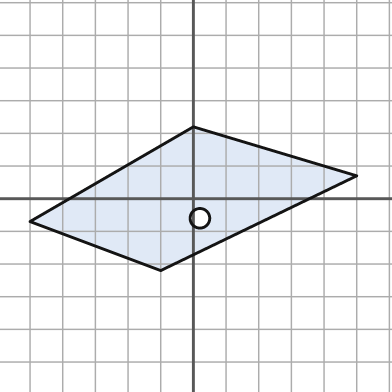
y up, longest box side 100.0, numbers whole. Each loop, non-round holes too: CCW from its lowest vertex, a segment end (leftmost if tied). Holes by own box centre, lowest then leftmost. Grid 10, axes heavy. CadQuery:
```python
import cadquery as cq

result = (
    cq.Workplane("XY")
    .moveTo(-10.0, -22.0)
    .lineTo(50.0, 7.0)
    .lineTo(0.0, 22.0)
    .lineTo(-50.0, -7.0)
    .close()
    .moveTo(2.0, -6.0)
    .circle(3.0)
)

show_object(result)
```